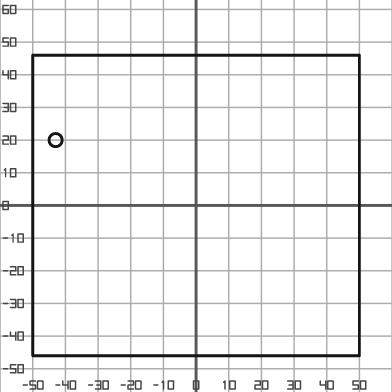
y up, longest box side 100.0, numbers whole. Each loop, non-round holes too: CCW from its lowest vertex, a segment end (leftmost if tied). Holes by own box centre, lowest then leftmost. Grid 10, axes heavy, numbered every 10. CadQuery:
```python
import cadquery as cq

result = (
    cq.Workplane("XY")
    .moveTo(-50.0, -46.0)
    .lineTo(50.0, -46.0)
    .lineTo(50.0, 46.0)
    .lineTo(-50.0, 46.0)
    .close()
    .moveTo(-43.0, 20.0)
    .circle(2.0)
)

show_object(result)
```